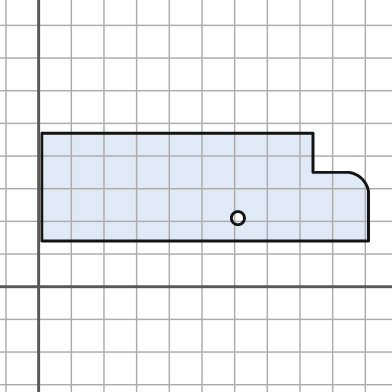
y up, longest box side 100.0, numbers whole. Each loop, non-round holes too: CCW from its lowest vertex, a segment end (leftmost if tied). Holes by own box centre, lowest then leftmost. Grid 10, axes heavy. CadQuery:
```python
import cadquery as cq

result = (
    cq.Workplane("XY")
    .moveTo(1.0, 14.0)
    .lineTo(101.0, 14.0)
    .lineTo(101.0, 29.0)
    .threePointArc((99.0, 33.0), (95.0, 35.0))
    .lineTo(84.0, 35.0)
    .lineTo(84.0, 47.0)
    .lineTo(1.0, 47.0)
    .close()
    .moveTo(61.0, 21.0)
    .circle(2.0)
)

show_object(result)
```